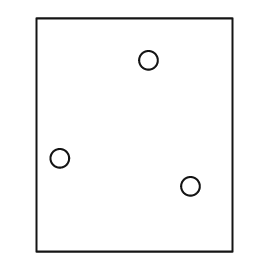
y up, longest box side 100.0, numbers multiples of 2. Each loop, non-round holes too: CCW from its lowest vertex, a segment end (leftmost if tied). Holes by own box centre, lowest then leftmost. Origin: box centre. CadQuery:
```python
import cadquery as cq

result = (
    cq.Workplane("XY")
    .moveTo(-42.0, -50.0)
    .lineTo(42.0, -50.0)
    .lineTo(42.0, 50.0)
    .lineTo(-42.0, 50.0)
    .close()
    .moveTo(24.0, -22.0)
    .circle(4.0)
    .moveTo(-32.0, -10.0)
    .circle(4.0)
    .moveTo(6.0, 32.0)
    .circle(4.0)
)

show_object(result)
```